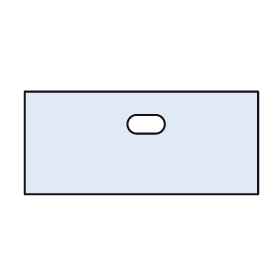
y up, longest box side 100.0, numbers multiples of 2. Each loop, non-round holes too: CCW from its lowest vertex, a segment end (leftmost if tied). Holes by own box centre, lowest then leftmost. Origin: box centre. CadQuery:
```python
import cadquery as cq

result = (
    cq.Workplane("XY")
    .moveTo(-50.0, -22.0)
    .lineTo(50.0, -22.0)
    .lineTo(50.0, 22.0)
    .lineTo(-50.0, 22.0)
    .close()
    .moveTo(-2.0, 4.0)
    .lineTo(6.0, 4.0)
    .threePointArc((10.0, 8.0), (6.0, 12.0))
    .lineTo(-2.0, 12.0)
    .threePointArc((-6.0, 8.0), (-2.0, 4.0))
    .close()
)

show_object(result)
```